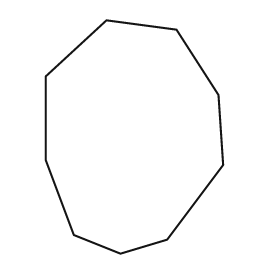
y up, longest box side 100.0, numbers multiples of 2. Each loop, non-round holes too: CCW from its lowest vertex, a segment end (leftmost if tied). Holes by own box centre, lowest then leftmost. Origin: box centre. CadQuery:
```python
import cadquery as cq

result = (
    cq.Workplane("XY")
    .moveTo(-6.0, -50.0)
    .lineTo(14.0, -44.0)
    .lineTo(38.0, -12.0)
    .lineTo(36.0, 18.0)
    .lineTo(18.0, 46.0)
    .lineTo(-12.0, 50.0)
    .lineTo(-38.0, 26.0)
    .lineTo(-38.0, -10.0)
    .lineTo(-26.0, -42.0)
    .close()
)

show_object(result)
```